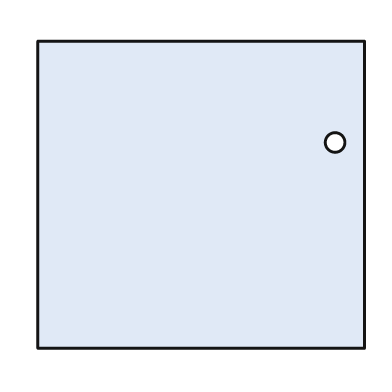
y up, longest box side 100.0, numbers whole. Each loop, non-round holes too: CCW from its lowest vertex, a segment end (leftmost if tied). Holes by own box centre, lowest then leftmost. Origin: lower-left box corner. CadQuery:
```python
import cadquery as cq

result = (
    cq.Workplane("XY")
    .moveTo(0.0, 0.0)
    .lineTo(100.0, 0.0)
    .lineTo(100.0, 94.0)
    .lineTo(0.0, 94.0)
    .close()
    .moveTo(91.0, 63.0)
    .circle(3.0)
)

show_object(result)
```